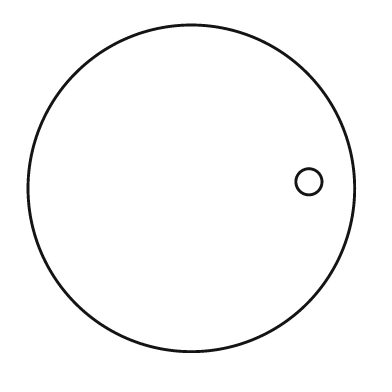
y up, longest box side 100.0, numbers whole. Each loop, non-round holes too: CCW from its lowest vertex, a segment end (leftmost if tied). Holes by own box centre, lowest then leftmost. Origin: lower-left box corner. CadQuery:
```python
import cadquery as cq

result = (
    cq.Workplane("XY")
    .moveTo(50.0, 50.0)
    .circle(50.0)
    .moveTo(86.0, 52.0)
    .circle(4.0)
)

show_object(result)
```